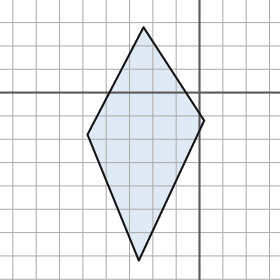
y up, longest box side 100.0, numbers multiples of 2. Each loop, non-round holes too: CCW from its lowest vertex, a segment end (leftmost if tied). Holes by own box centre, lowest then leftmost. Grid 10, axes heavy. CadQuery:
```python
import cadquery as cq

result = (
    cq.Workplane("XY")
    .moveTo(-26.0, -72.0)
    .lineTo(2.0, -12.0)
    .lineTo(-24.0, 28.0)
    .lineTo(-48.0, -18.0)
    .close()
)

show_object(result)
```